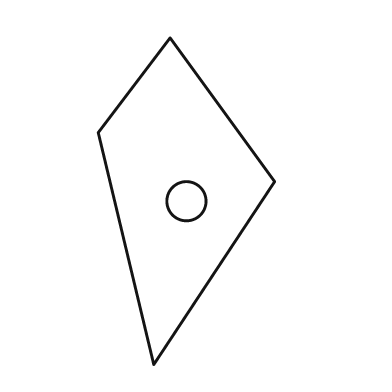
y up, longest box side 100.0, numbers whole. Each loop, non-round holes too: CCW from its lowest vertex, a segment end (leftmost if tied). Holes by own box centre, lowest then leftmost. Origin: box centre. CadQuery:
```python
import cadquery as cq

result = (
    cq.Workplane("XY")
    .moveTo(-10.0, -50.0)
    .lineTo(27.0, 6.0)
    .lineTo(-5.0, 50.0)
    .lineTo(-27.0, 21.0)
    .close()
    .moveTo(0.0, 0.0)
    .circle(6.0)
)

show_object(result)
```